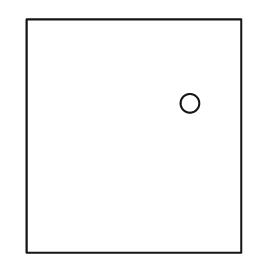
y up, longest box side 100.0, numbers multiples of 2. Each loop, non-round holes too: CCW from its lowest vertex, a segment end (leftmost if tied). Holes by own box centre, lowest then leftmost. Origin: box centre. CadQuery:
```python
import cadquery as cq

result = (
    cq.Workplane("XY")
    .moveTo(-46.0, -50.0)
    .lineTo(46.0, -50.0)
    .lineTo(46.0, 50.0)
    .lineTo(-46.0, 50.0)
    .close()
    .moveTo(24.0, 14.0)
    .circle(4.0)
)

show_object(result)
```